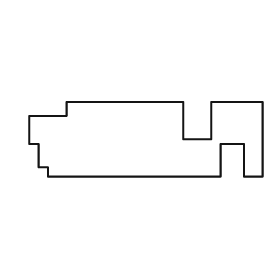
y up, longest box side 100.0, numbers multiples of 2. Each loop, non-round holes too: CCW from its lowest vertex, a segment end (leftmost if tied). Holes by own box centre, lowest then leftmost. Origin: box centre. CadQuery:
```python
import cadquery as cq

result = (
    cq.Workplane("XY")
    .moveTo(-42.0, -16.0)
    .lineTo(32.0, -16.0)
    .lineTo(32.0, -2.0)
    .lineTo(42.0, -2.0)
    .lineTo(42.0, -16.0)
    .lineTo(50.0, -16.0)
    .lineTo(50.0, 16.0)
    .lineTo(28.0, 16.0)
    .lineTo(28.0, 0.0)
    .lineTo(16.0, 0.0)
    .lineTo(16.0, 16.0)
    .lineTo(-34.0, 16.0)
    .lineTo(-34.0, 10.0)
    .lineTo(-50.0, 10.0)
    .lineTo(-50.0, -2.0)
    .lineTo(-46.0, -2.0)
    .lineTo(-46.0, -12.0)
    .lineTo(-42.0, -12.0)
    .close()
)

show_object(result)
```